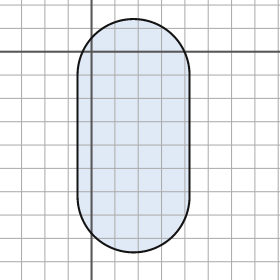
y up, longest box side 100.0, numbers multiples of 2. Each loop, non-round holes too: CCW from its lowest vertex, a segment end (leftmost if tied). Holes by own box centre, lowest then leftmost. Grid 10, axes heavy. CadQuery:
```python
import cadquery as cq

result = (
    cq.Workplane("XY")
    .moveTo(-6.0, -62.0)
    .threePointArc((18.0, -86.0), (42.0, -62.0))
    .lineTo(42.0, -10.0)
    .threePointArc((18.0, 14.0), (-6.0, -10.0))
    .close()
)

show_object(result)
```